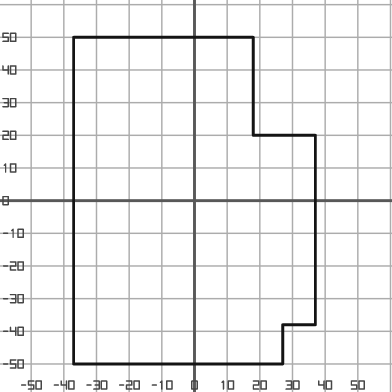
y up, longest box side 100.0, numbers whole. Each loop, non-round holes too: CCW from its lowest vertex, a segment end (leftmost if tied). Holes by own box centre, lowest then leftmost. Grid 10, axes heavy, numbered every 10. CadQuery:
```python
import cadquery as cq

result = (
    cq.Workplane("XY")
    .moveTo(-37.0, -50.0)
    .lineTo(27.0, -50.0)
    .lineTo(27.0, -38.0)
    .lineTo(37.0, -38.0)
    .lineTo(37.0, 20.0)
    .lineTo(18.0, 20.0)
    .lineTo(18.0, 50.0)
    .lineTo(-37.0, 50.0)
    .close()
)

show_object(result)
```